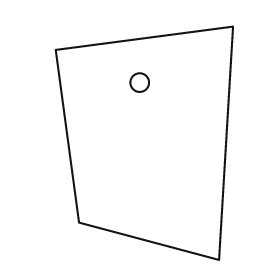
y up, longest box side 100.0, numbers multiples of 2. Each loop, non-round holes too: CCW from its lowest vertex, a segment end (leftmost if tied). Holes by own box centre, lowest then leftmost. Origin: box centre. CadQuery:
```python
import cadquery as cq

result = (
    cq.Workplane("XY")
    .moveTo(32.0, -50.0)
    .lineTo(38.0, 50.0)
    .lineTo(-38.0, 40.0)
    .lineTo(-28.0, -34.0)
    .close()
    .moveTo(-2.0, 26.0)
    .circle(4.0)
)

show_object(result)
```